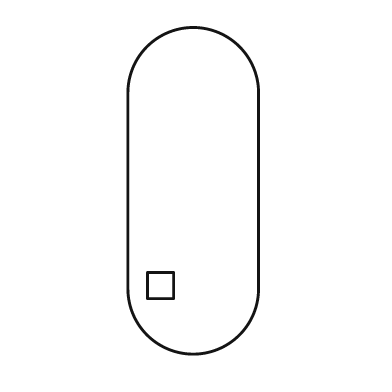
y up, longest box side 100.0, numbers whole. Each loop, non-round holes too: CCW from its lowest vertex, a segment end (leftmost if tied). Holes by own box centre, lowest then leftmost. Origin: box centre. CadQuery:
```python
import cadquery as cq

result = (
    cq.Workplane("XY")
    .moveTo(-20.0, -30.0)
    .threePointArc((0.0, -50.0), (20.0, -30.0))
    .lineTo(20.0, 30.0)
    .threePointArc((0.0, 50.0), (-20.0, 30.0))
    .close()
    .moveTo(-14.0, -33.0)
    .lineTo(-6.0, -33.0)
    .lineTo(-6.0, -25.0)
    .lineTo(-14.0, -25.0)
    .close()
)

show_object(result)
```